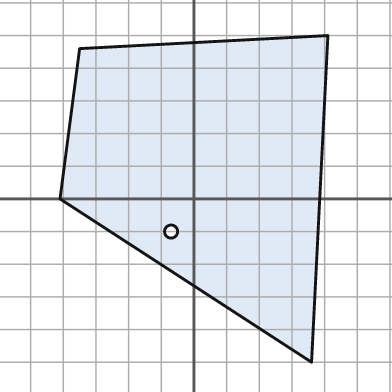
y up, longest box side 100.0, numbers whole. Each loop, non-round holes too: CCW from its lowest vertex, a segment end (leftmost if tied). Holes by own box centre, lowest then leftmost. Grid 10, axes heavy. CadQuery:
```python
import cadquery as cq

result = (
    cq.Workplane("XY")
    .moveTo(36.0, -50.0)
    .lineTo(41.0, 50.0)
    .lineTo(-35.0, 46.0)
    .lineTo(-41.0, 0.0)
    .close()
    .moveTo(-7.0, -10.0)
    .circle(2.0)
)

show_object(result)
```